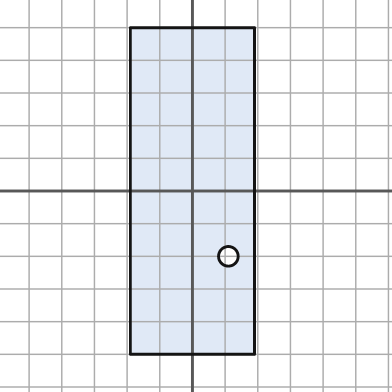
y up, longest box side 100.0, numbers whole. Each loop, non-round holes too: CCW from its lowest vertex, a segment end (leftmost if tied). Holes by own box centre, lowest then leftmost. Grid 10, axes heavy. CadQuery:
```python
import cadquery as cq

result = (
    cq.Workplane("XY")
    .moveTo(-19.0, -50.0)
    .lineTo(19.0, -50.0)
    .lineTo(19.0, 50.0)
    .lineTo(-19.0, 50.0)
    .close()
    .moveTo(11.0, -20.0)
    .circle(3.0)
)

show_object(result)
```